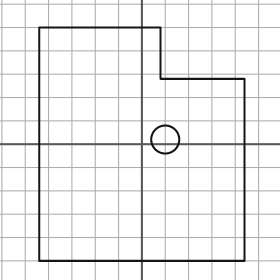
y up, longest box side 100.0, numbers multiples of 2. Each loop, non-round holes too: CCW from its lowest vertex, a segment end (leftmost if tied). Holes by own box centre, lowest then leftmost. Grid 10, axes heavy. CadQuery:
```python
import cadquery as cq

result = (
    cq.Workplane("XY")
    .moveTo(-44.0, -50.0)
    .lineTo(44.0, -50.0)
    .lineTo(44.0, 28.0)
    .lineTo(8.0, 28.0)
    .lineTo(8.0, 50.0)
    .lineTo(-44.0, 50.0)
    .close()
    .moveTo(10.0, 2.0)
    .circle(6.0)
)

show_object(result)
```